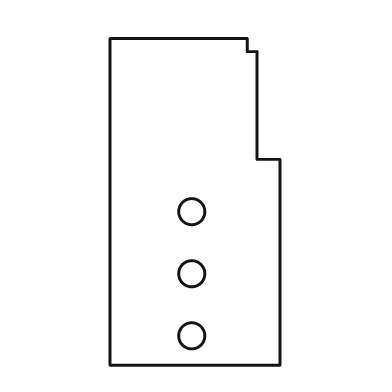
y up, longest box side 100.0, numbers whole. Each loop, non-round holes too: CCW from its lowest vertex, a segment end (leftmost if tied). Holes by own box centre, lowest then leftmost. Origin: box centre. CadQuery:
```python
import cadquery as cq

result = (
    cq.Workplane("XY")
    .moveTo(-26.0, -50.0)
    .lineTo(26.0, -50.0)
    .lineTo(26.0, 13.0)
    .lineTo(19.0, 13.0)
    .lineTo(19.0, 46.0)
    .lineTo(16.0, 46.0)
    .lineTo(16.0, 50.0)
    .lineTo(-26.0, 50.0)
    .close()
    .moveTo(-1.0, -41.0)
    .circle(4.0)
    .moveTo(-1.0, -22.0)
    .circle(4.0)
    .moveTo(-1.0, -3.0)
    .circle(4.0)
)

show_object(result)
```